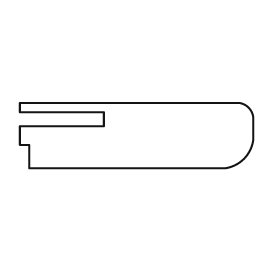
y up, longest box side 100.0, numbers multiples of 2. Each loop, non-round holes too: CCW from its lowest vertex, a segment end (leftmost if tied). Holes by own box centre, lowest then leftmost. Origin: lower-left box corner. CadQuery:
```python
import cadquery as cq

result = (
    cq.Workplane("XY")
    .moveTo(4.0, 0.0)
    .lineTo(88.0, 0.0)
    .threePointArc((96.0, 4.0), (100.0, 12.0))
    .lineTo(100.0, 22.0)
    .threePointArc((98.0, 26.0), (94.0, 28.0))
    .lineTo(0.0, 28.0)
    .lineTo(0.0, 24.0)
    .lineTo(36.0, 24.0)
    .lineTo(36.0, 18.0)
    .lineTo(0.0, 18.0)
    .lineTo(0.0, 10.0)
    .lineTo(4.0, 10.0)
    .close()
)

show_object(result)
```